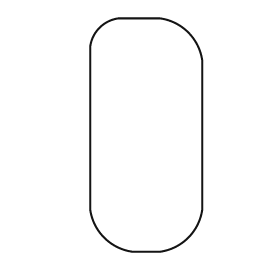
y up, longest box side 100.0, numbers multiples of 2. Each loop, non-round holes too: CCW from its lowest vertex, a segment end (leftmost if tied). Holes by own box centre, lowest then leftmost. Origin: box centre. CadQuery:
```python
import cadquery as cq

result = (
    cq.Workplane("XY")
    .moveTo(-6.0, -50.0)
    .lineTo(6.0, -50.0)
    .threePointArc((18.0, -44.0), (24.0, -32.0))
    .lineTo(24.0, 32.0)
    .threePointArc((18.0, 44.0), (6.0, 50.0))
    .lineTo(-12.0, 50.0)
    .threePointArc((-20.0, 46.0), (-24.0, 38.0))
    .lineTo(-24.0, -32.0)
    .threePointArc((-18.0, -44.0), (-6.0, -50.0))
    .close()
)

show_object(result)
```